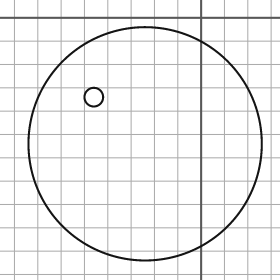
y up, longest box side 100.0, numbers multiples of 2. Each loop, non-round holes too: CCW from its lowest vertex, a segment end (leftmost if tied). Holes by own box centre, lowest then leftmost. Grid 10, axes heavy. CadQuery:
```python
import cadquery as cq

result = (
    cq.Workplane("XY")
    .moveTo(-24.0, -54.0)
    .circle(50.0)
    .moveTo(-46.0, -34.0)
    .circle(4.0)
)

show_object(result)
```